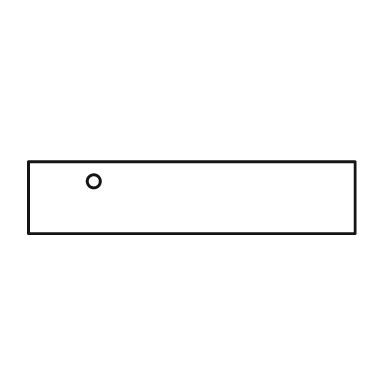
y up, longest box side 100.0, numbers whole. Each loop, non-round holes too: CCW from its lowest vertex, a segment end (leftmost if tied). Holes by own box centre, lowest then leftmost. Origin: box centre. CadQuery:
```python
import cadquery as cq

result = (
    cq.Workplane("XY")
    .moveTo(-50.0, -11.0)
    .lineTo(50.0, -11.0)
    .lineTo(50.0, 11.0)
    .lineTo(-50.0, 11.0)
    .close()
    .moveTo(-30.0, 5.0)
    .circle(2.0)
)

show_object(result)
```